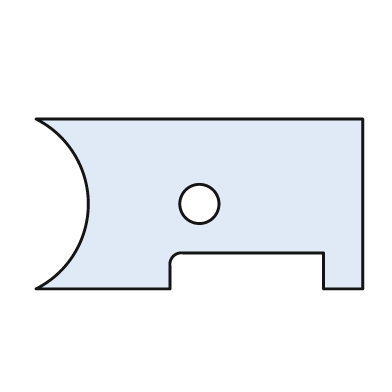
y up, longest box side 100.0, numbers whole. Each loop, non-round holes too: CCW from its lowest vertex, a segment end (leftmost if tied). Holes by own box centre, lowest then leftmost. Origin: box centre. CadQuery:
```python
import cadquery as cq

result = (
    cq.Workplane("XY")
    .moveTo(-50.0, -26.0)
    .lineTo(-9.0, -26.0)
    .lineTo(-9.0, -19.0)
    .threePointArc((-8.0, -16.0), (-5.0, -15.0))
    .lineTo(38.0, -15.0)
    .lineTo(38.0, -26.0)
    .lineTo(50.0, -26.0)
    .lineTo(50.0, 26.0)
    .lineTo(-50.0, 26.0)
    .threePointArc((-34.0, 0.0), (-50.0, -26.0))
    .close()
    .moveTo(0.0, 0.0)
    .circle(6.0)
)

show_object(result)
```